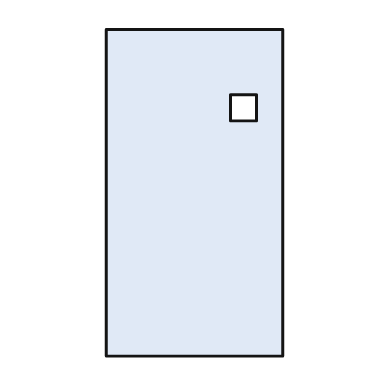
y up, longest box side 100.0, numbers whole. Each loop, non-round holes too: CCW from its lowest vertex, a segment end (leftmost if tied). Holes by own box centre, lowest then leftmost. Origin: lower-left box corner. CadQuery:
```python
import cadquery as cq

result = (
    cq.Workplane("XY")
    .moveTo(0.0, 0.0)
    .lineTo(54.0, 0.0)
    .lineTo(54.0, 100.0)
    .lineTo(0.0, 100.0)
    .close()
    .moveTo(38.0, 72.0)
    .lineTo(46.0, 72.0)
    .lineTo(46.0, 80.0)
    .lineTo(38.0, 80.0)
    .close()
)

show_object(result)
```